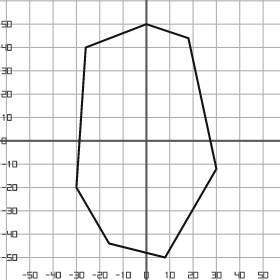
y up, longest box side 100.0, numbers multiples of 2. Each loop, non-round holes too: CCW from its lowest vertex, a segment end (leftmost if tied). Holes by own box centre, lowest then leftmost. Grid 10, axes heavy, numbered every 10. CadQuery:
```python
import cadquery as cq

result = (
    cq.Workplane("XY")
    .moveTo(8.0, -50.0)
    .lineTo(30.0, -12.0)
    .lineTo(18.0, 44.0)
    .lineTo(0.0, 50.0)
    .lineTo(-26.0, 40.0)
    .lineTo(-30.0, -20.0)
    .lineTo(-16.0, -44.0)
    .close()
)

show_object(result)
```